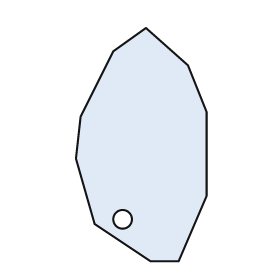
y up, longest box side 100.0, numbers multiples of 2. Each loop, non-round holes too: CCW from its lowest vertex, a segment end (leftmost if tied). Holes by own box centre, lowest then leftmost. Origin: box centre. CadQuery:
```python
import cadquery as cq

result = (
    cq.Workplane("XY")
    .moveTo(4.0, -50.0)
    .lineTo(16.0, -50.0)
    .lineTo(28.0, -22.0)
    .lineTo(28.0, 14.0)
    .lineTo(20.0, 34.0)
    .lineTo(2.0, 50.0)
    .lineTo(-12.0, 40.0)
    .lineTo(-26.0, 12.0)
    .lineTo(-28.0, -6.0)
    .lineTo(-20.0, -34.0)
    .close()
    .moveTo(-8.0, -32.0)
    .circle(4.0)
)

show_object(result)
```